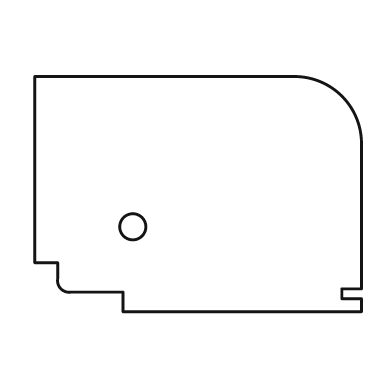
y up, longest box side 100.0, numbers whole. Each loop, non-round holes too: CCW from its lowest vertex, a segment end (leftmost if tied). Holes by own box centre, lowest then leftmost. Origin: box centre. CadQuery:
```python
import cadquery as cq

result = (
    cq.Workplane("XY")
    .moveTo(-23.0, -36.0)
    .lineTo(50.0, -36.0)
    .lineTo(50.0, -32.0)
    .lineTo(44.0, -32.0)
    .lineTo(44.0, -29.0)
    .lineTo(50.0, -29.0)
    .lineTo(50.0, 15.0)
    .threePointArc((44.0, 30.0), (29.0, 36.0))
    .lineTo(-50.0, 36.0)
    .lineTo(-50.0, -21.0)
    .lineTo(-43.0, -21.0)
    .lineTo(-43.0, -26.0)
    .threePointArc((-42.0, -29.0), (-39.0, -30.0))
    .lineTo(-23.0, -30.0)
    .close()
    .moveTo(-20.0, -10.0)
    .circle(4.0)
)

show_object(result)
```